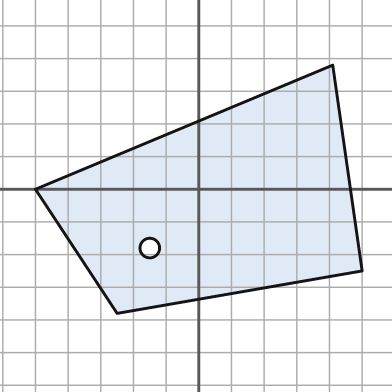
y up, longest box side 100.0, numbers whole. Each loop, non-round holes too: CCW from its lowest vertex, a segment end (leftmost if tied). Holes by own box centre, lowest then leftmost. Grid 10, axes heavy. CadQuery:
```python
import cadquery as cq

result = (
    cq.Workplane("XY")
    .moveTo(-25.0, -38.0)
    .lineTo(50.0, -25.0)
    .lineTo(41.0, 38.0)
    .lineTo(-50.0, 0.0)
    .close()
    .moveTo(-15.0, -18.0)
    .circle(3.0)
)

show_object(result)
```